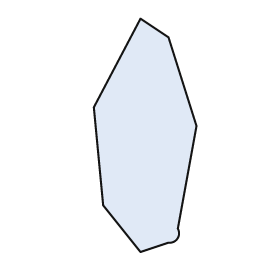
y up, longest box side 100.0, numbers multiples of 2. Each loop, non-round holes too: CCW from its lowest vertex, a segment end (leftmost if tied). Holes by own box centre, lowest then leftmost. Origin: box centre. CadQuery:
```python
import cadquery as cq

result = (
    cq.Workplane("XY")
    .moveTo(-2.0, -50.0)
    .lineTo(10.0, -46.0)
    .threePointArc((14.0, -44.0), (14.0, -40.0))
    .lineTo(22.0, 4.0)
    .lineTo(10.0, 42.0)
    .lineTo(-2.0, 50.0)
    .lineTo(-22.0, 12.0)
    .lineTo(-18.0, -30.0)
    .close()
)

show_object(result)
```